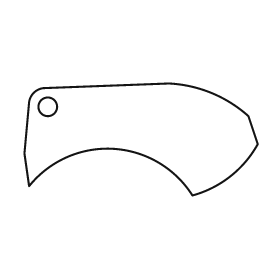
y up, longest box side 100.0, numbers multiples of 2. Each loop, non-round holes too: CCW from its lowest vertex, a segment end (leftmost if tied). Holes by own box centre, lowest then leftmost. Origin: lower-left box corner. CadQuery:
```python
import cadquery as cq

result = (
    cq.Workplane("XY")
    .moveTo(72.0, 0.0)
    .threePointArc((88.0, 8.0), (100.0, 22.0))
    .lineTo(96.0, 34.0)
    .threePointArc((80.0, 44.0), (62.0, 48.0))
    .lineTo(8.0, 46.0)
    .threePointArc((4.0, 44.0), (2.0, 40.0))
    .lineTo(0.0, 18.0)
    .lineTo(2.0, 4.0)
    .threePointArc((38.0, 20.0), (72.0, 0.0))
    .close()
    .moveTo(10.0, 38.0)
    .circle(4.0)
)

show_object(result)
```